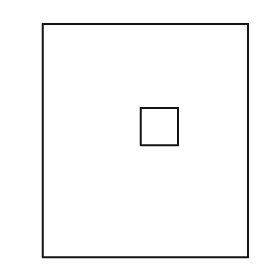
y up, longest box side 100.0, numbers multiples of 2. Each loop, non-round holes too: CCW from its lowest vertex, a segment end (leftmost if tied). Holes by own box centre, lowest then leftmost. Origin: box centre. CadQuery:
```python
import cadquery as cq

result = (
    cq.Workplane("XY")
    .moveTo(-44.0, -50.0)
    .lineTo(44.0, -50.0)
    .lineTo(44.0, 50.0)
    .lineTo(-44.0, 50.0)
    .close()
    .moveTo(-2.0, -2.0)
    .lineTo(14.0, -2.0)
    .lineTo(14.0, 14.0)
    .lineTo(-2.0, 14.0)
    .close()
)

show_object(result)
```